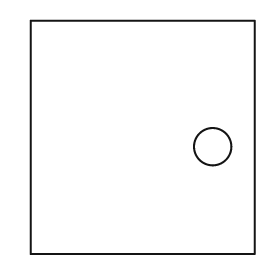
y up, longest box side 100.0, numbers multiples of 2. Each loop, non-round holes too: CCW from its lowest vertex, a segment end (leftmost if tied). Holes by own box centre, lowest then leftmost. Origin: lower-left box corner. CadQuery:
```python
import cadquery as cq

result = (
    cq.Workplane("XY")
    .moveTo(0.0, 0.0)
    .lineTo(96.0, 0.0)
    .lineTo(96.0, 100.0)
    .lineTo(0.0, 100.0)
    .close()
    .moveTo(78.0, 46.0)
    .circle(8.0)
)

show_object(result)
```